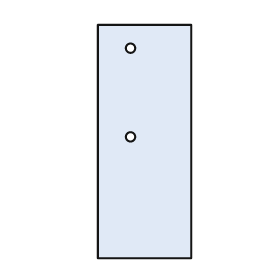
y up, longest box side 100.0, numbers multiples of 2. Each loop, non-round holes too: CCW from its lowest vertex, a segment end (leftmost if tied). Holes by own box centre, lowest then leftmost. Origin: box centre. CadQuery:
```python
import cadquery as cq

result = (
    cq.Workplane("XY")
    .moveTo(-20.0, -50.0)
    .lineTo(20.0, -50.0)
    .lineTo(20.0, 50.0)
    .lineTo(-20.0, 50.0)
    .close()
    .moveTo(-6.0, 2.0)
    .circle(2.0)
    .moveTo(-6.0, 40.0)
    .circle(2.0)
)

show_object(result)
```